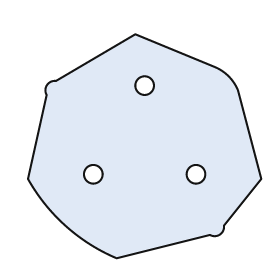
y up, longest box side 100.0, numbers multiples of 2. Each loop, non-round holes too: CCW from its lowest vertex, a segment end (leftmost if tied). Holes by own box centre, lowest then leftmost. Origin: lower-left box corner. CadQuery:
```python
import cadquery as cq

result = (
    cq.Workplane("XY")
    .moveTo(38.0, 0.0)
    .lineTo(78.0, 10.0)
    .threePointArc((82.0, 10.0), (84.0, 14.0))
    .lineTo(100.0, 34.0)
    .lineTo(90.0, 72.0)
    .threePointArc((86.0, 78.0), (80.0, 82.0))
    .lineTo(46.0, 96.0)
    .lineTo(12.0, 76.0)
    .threePointArc((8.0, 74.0), (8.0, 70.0))
    .lineTo(0.0, 34.0)
    .threePointArc((16.0, 14.0), (38.0, 0.0))
    .close()
    .moveTo(28.0, 36.0)
    .circle(4.0)
    .moveTo(72.0, 36.0)
    .circle(4.0)
    .moveTo(50.0, 74.0)
    .circle(4.0)
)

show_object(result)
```